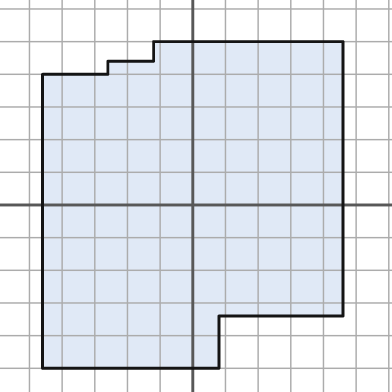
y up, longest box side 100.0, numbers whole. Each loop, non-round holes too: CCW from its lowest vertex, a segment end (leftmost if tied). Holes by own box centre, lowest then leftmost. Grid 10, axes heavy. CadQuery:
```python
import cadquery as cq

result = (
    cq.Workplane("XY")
    .moveTo(-46.0, -50.0)
    .lineTo(8.0, -50.0)
    .lineTo(8.0, -34.0)
    .lineTo(46.0, -34.0)
    .lineTo(46.0, 50.0)
    .lineTo(-12.0, 50.0)
    .lineTo(-12.0, 44.0)
    .lineTo(-26.0, 44.0)
    .lineTo(-26.0, 40.0)
    .lineTo(-46.0, 40.0)
    .close()
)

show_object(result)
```